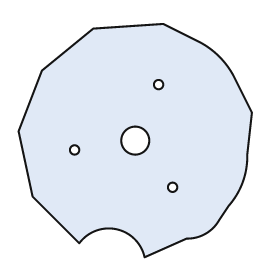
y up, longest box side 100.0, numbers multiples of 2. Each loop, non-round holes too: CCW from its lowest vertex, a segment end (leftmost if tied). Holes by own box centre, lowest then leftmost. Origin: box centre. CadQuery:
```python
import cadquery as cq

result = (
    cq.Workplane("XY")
    .moveTo(4.0, -50.0)
    .lineTo(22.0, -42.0)
    .threePointArc((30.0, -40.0), (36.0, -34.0))
    .lineTo(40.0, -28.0)
    .threePointArc((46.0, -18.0), (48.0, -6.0))
    .lineTo(50.0, 12.0)
    .lineTo(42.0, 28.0)
    .threePointArc((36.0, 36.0), (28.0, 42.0))
    .lineTo(12.0, 50.0)
    .lineTo(-18.0, 48.0)
    .lineTo(-40.0, 30.0)
    .lineTo(-50.0, 4.0)
    .lineTo(-44.0, -24.0)
    .lineTo(-24.0, -44.0)
    .threePointArc((-8.0, -38.0), (4.0, -50.0))
    .close()
    .moveTo(16.0, -20.0)
    .circle(2.0)
    .moveTo(-26.0, -4.0)
    .circle(2.0)
    .moveTo(0.0, 0.0)
    .circle(6.0)
    .moveTo(10.0, 24.0)
    .circle(2.0)
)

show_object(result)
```